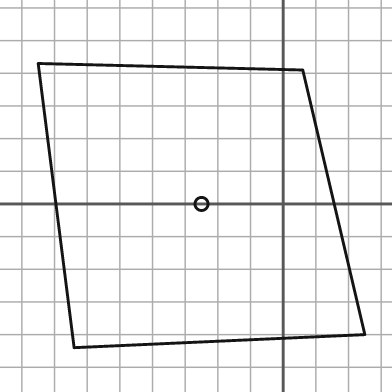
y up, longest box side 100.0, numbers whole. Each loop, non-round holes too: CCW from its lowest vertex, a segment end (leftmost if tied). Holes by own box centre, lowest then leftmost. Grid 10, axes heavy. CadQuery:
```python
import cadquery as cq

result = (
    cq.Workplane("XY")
    .moveTo(-64.0, -44.0)
    .lineTo(25.0, -40.0)
    .lineTo(6.0, 41.0)
    .lineTo(-75.0, 43.0)
    .close()
    .moveTo(-25.0, 0.0)
    .circle(2.0)
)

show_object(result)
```